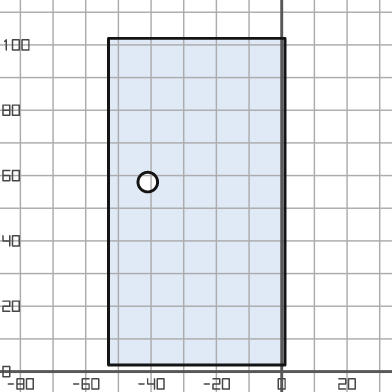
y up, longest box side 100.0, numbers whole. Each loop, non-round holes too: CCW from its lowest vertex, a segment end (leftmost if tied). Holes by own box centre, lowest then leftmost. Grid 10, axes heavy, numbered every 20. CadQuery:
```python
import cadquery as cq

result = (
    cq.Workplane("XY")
    .moveTo(-53.0, 2.0)
    .lineTo(1.0, 2.0)
    .lineTo(1.0, 102.0)
    .lineTo(-53.0, 102.0)
    .close()
    .moveTo(-41.0, 58.0)
    .circle(3.0)
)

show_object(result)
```